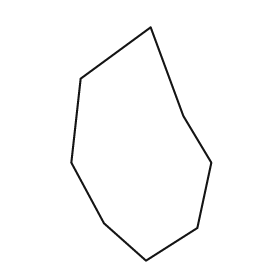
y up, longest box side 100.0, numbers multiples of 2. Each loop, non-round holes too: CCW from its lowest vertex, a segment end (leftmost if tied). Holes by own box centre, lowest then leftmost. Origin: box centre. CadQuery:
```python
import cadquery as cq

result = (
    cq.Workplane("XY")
    .moveTo(2.0, -50.0)
    .lineTo(24.0, -36.0)
    .lineTo(30.0, -8.0)
    .lineTo(18.0, 12.0)
    .lineTo(4.0, 50.0)
    .lineTo(-26.0, 28.0)
    .lineTo(-30.0, -8.0)
    .lineTo(-16.0, -34.0)
    .close()
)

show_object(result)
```